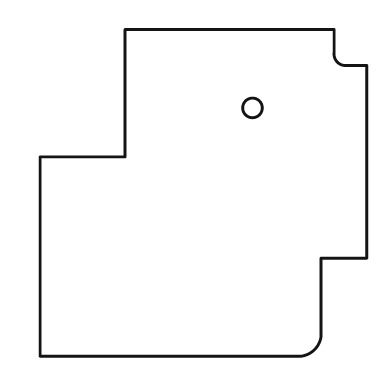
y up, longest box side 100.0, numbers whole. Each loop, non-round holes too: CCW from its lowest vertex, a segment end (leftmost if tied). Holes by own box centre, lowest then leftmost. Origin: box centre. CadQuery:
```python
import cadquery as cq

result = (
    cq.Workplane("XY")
    .moveTo(-50.0, -50.0)
    .lineTo(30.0, -50.0)
    .threePointArc((34.0, -48.0), (36.0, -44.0))
    .lineTo(36.0, -20.0)
    .lineTo(50.0, -20.0)
    .lineTo(50.0, 39.0)
    .lineTo(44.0, 39.0)
    .threePointArc((41.0, 40.0), (40.0, 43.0))
    .lineTo(40.0, 50.0)
    .lineTo(-24.0, 50.0)
    .lineTo(-24.0, 11.0)
    .lineTo(-50.0, 11.0)
    .close()
    .moveTo(15.0, 26.0)
    .circle(3.0)
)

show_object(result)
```